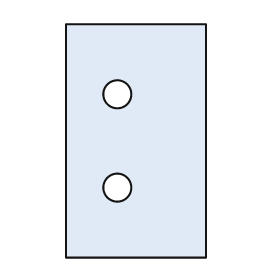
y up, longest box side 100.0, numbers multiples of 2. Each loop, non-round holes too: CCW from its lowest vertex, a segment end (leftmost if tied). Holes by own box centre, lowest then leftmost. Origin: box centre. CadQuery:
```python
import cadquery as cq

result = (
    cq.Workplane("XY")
    .moveTo(-30.0, -50.0)
    .lineTo(30.0, -50.0)
    .lineTo(30.0, 50.0)
    .lineTo(-30.0, 50.0)
    .close()
    .moveTo(-8.0, -20.0)
    .circle(6.0)
    .moveTo(-8.0, 20.0)
    .circle(6.0)
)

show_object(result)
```